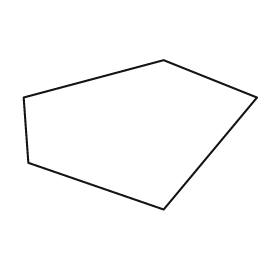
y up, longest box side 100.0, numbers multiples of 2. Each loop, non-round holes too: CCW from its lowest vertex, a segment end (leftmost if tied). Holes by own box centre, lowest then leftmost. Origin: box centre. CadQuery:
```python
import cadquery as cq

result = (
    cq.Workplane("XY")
    .moveTo(10.0, -32.0)
    .lineTo(50.0, 16.0)
    .lineTo(10.0, 32.0)
    .lineTo(-50.0, 16.0)
    .lineTo(-48.0, -12.0)
    .close()
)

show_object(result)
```